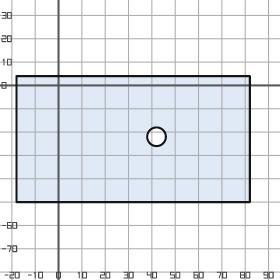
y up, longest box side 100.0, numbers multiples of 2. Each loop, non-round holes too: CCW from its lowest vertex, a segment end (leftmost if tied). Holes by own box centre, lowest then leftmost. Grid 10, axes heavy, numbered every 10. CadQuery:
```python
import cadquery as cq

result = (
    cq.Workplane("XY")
    .moveTo(-18.0, -50.0)
    .lineTo(82.0, -50.0)
    .lineTo(82.0, 4.0)
    .lineTo(-18.0, 4.0)
    .close()
    .moveTo(42.0, -22.0)
    .circle(4.0)
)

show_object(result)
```